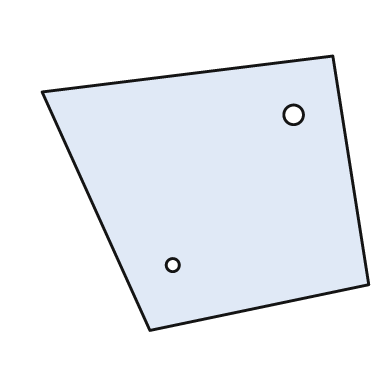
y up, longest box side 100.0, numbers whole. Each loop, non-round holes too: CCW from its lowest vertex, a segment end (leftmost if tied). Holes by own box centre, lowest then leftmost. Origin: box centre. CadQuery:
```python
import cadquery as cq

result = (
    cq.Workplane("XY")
    .moveTo(-17.0, -42.0)
    .lineTo(50.0, -28.0)
    .lineTo(39.0, 42.0)
    .lineTo(-50.0, 31.0)
    .close()
    .moveTo(-10.0, -22.0)
    .circle(2.0)
    .moveTo(27.0, 24.0)
    .circle(3.0)
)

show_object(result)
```